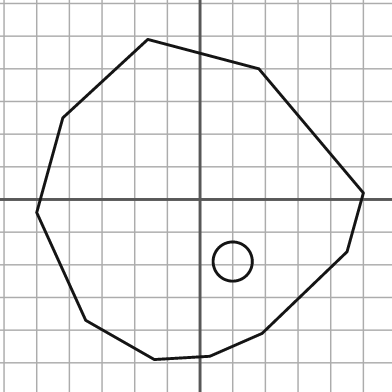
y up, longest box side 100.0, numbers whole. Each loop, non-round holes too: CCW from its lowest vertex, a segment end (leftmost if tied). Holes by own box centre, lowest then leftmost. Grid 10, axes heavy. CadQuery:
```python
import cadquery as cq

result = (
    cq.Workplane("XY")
    .moveTo(-14.0, -49.0)
    .lineTo(3.0, -48.0)
    .lineTo(19.0, -41.0)
    .lineTo(45.0, -16.0)
    .lineTo(50.0, 2.0)
    .lineTo(18.0, 40.0)
    .lineTo(-16.0, 49.0)
    .lineTo(-42.0, 25.0)
    .lineTo(-50.0, -4.0)
    .lineTo(-35.0, -37.0)
    .close()
    .moveTo(10.0, -19.0)
    .circle(6.0)
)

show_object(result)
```